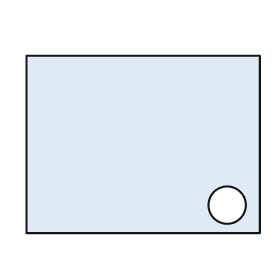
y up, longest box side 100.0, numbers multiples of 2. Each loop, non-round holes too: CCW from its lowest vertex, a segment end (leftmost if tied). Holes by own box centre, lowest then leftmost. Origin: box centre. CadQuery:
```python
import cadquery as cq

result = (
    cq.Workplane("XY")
    .moveTo(-50.0, -38.0)
    .lineTo(50.0, -38.0)
    .lineTo(50.0, 38.0)
    .lineTo(-50.0, 38.0)
    .close()
    .moveTo(36.0, -26.0)
    .circle(8.0)
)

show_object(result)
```